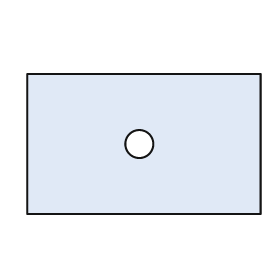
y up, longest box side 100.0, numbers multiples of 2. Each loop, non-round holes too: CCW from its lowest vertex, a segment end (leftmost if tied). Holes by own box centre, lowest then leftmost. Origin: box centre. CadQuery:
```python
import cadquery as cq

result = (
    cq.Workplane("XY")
    .moveTo(-50.0, -30.0)
    .lineTo(50.0, -30.0)
    .lineTo(50.0, 30.0)
    .lineTo(-50.0, 30.0)
    .close()
    .moveTo(-2.0, 0.0)
    .circle(6.0)
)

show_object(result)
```